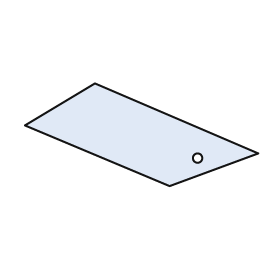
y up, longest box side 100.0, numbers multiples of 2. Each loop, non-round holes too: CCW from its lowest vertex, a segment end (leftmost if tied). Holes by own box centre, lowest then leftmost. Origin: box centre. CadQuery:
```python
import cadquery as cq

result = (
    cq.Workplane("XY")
    .moveTo(12.0, -22.0)
    .lineTo(50.0, -8.0)
    .lineTo(-20.0, 22.0)
    .lineTo(-50.0, 4.0)
    .close()
    .moveTo(24.0, -10.0)
    .circle(2.0)
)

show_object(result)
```